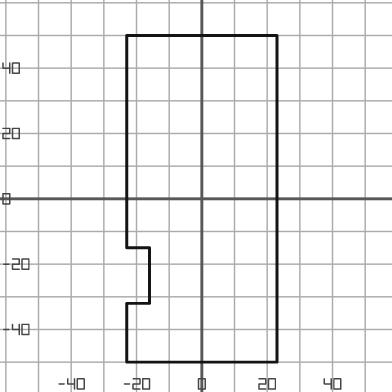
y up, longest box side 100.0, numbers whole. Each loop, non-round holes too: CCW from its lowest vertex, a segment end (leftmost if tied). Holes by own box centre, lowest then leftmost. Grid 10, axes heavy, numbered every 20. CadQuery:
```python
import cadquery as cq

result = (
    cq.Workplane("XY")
    .moveTo(-23.0, -50.0)
    .lineTo(23.0, -50.0)
    .lineTo(23.0, 50.0)
    .lineTo(-23.0, 50.0)
    .lineTo(-23.0, -15.0)
    .lineTo(-16.0, -15.0)
    .lineTo(-16.0, -32.0)
    .lineTo(-23.0, -32.0)
    .close()
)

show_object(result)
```